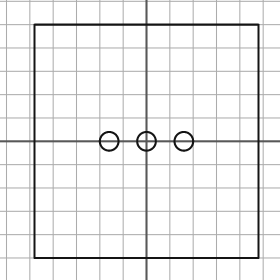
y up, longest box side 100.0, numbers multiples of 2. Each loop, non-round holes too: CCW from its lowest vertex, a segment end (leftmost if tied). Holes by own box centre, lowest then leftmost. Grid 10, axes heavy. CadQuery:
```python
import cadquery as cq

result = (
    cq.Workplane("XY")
    .moveTo(-48.0, -50.0)
    .lineTo(48.0, -50.0)
    .lineTo(48.0, 50.0)
    .lineTo(-48.0, 50.0)
    .close()
    .moveTo(-16.0, 0.0)
    .circle(4.0)
    .moveTo(0.0, 0.0)
    .circle(4.0)
    .moveTo(16.0, 0.0)
    .circle(4.0)
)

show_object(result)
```